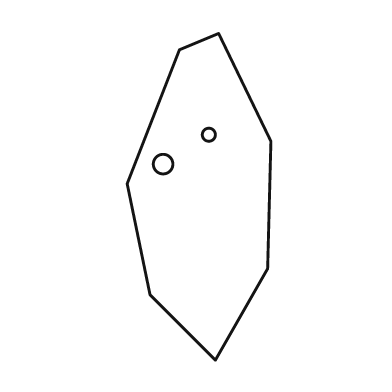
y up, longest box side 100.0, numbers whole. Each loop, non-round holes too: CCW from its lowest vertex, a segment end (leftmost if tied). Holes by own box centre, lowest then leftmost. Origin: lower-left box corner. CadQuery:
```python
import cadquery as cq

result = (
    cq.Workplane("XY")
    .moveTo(27.0, 0.0)
    .lineTo(43.0, 28.0)
    .lineTo(44.0, 67.0)
    .lineTo(28.0, 100.0)
    .lineTo(16.0, 95.0)
    .lineTo(0.0, 54.0)
    .lineTo(7.0, 20.0)
    .close()
    .moveTo(11.0, 60.0)
    .circle(3.0)
    .moveTo(25.0, 69.0)
    .circle(2.0)
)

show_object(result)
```